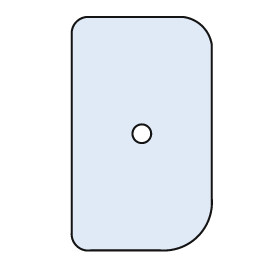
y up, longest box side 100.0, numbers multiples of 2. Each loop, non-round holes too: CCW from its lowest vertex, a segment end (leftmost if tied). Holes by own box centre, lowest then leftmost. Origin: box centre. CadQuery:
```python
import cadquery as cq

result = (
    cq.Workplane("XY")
    .moveTo(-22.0, -50.0)
    .lineTo(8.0, -50.0)
    .threePointArc((24.0, -44.0), (30.0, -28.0))
    .lineTo(30.0, 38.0)
    .threePointArc((26.0, 46.0), (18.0, 50.0))
    .lineTo(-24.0, 50.0)
    .threePointArc((-28.0, 48.0), (-30.0, 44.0))
    .lineTo(-30.0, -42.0)
    .threePointArc((-28.0, -48.0), (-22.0, -50.0))
    .close()
    .moveTo(0.0, 0.0)
    .circle(4.0)
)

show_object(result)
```